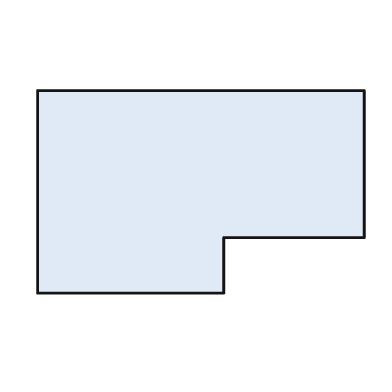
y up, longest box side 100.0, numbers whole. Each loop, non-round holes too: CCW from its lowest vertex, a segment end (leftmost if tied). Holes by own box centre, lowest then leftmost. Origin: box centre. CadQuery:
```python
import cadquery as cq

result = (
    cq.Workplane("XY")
    .moveTo(-50.0, -31.0)
    .lineTo(7.0, -31.0)
    .lineTo(7.0, -14.0)
    .lineTo(50.0, -14.0)
    .lineTo(50.0, 31.0)
    .lineTo(-50.0, 31.0)
    .close()
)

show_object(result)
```